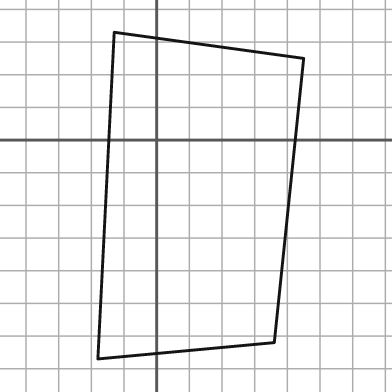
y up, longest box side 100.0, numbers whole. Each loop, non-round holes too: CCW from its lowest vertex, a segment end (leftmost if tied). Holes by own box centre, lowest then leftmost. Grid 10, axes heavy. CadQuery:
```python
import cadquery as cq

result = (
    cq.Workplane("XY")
    .moveTo(-18.0, -67.0)
    .lineTo(36.0, -62.0)
    .lineTo(45.0, 25.0)
    .lineTo(-13.0, 33.0)
    .close()
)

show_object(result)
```